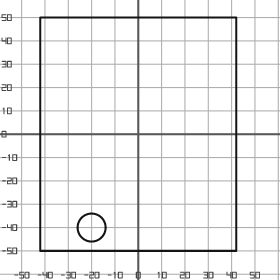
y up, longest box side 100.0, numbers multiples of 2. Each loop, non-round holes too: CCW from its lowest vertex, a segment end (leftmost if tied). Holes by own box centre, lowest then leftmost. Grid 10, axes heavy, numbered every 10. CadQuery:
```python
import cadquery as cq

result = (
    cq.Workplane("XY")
    .moveTo(-42.0, -50.0)
    .lineTo(42.0, -50.0)
    .lineTo(42.0, 50.0)
    .lineTo(-42.0, 50.0)
    .close()
    .moveTo(-20.0, -40.0)
    .circle(6.0)
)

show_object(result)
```